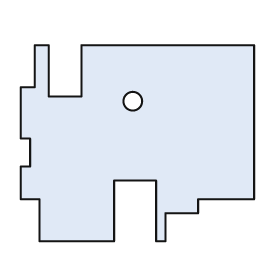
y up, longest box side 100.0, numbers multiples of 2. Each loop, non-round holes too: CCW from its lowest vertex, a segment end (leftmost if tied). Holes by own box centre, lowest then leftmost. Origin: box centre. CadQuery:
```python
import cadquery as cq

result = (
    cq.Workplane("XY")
    .moveTo(-42.0, -42.0)
    .lineTo(-10.0, -42.0)
    .lineTo(-10.0, -16.0)
    .lineTo(8.0, -16.0)
    .lineTo(8.0, -42.0)
    .lineTo(12.0, -42.0)
    .lineTo(12.0, -30.0)
    .lineTo(26.0, -30.0)
    .lineTo(26.0, -24.0)
    .lineTo(50.0, -24.0)
    .lineTo(50.0, 42.0)
    .lineTo(-24.0, 42.0)
    .lineTo(-24.0, 20.0)
    .lineTo(-38.0, 20.0)
    .lineTo(-38.0, 42.0)
    .lineTo(-44.0, 42.0)
    .lineTo(-44.0, 24.0)
    .lineTo(-50.0, 24.0)
    .lineTo(-50.0, 2.0)
    .lineTo(-46.0, 2.0)
    .lineTo(-46.0, -10.0)
    .lineTo(-50.0, -10.0)
    .lineTo(-50.0, -24.0)
    .lineTo(-42.0, -24.0)
    .close()
    .moveTo(-2.0, 18.0)
    .circle(4.0)
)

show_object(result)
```